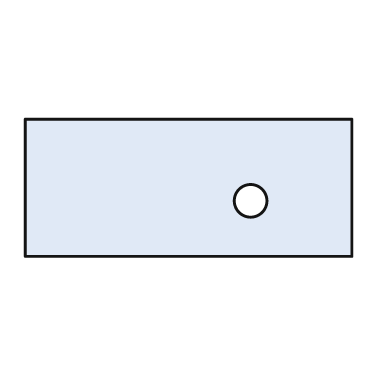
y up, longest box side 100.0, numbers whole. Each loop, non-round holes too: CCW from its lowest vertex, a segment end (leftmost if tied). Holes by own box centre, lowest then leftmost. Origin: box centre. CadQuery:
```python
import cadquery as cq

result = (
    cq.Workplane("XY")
    .moveTo(-50.0, -21.0)
    .lineTo(50.0, -21.0)
    .lineTo(50.0, 21.0)
    .lineTo(-50.0, 21.0)
    .close()
    .moveTo(19.0, -4.0)
    .circle(5.0)
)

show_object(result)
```